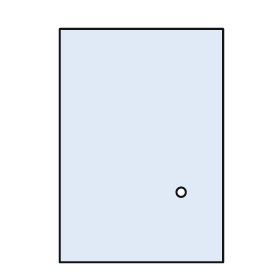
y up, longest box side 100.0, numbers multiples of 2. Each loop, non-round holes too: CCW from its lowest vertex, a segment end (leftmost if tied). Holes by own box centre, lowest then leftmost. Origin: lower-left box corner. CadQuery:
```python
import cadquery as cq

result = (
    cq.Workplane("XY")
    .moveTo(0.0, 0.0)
    .lineTo(70.0, 0.0)
    .lineTo(70.0, 100.0)
    .lineTo(0.0, 100.0)
    .close()
    .moveTo(52.0, 30.0)
    .circle(2.0)
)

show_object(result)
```